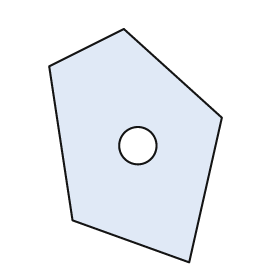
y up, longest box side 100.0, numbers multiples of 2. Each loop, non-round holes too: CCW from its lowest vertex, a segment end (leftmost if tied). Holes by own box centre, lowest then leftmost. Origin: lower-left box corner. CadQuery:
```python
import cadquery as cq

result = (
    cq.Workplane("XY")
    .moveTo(60.0, 0.0)
    .lineTo(74.0, 62.0)
    .lineTo(32.0, 100.0)
    .lineTo(0.0, 84.0)
    .lineTo(10.0, 18.0)
    .close()
    .moveTo(38.0, 50.0)
    .circle(8.0)
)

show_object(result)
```